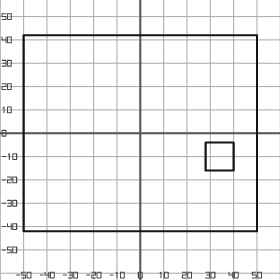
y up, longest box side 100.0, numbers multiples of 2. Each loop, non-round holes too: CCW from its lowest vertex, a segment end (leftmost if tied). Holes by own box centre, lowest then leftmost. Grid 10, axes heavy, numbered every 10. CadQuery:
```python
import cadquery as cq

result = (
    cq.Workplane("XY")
    .moveTo(-50.0, -42.0)
    .lineTo(50.0, -42.0)
    .lineTo(50.0, 42.0)
    .lineTo(-50.0, 42.0)
    .close()
    .moveTo(28.0, -16.0)
    .lineTo(40.0, -16.0)
    .lineTo(40.0, -4.0)
    .lineTo(28.0, -4.0)
    .close()
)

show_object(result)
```